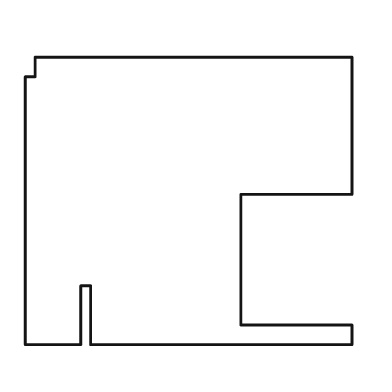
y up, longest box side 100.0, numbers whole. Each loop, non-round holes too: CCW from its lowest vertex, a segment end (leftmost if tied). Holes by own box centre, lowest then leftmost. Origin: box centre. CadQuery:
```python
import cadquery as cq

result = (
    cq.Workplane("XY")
    .moveTo(-50.0, -44.0)
    .lineTo(-33.0, -44.0)
    .lineTo(-33.0, -26.0)
    .lineTo(-30.0, -26.0)
    .lineTo(-30.0, -44.0)
    .lineTo(50.0, -44.0)
    .lineTo(50.0, -38.0)
    .lineTo(16.0, -38.0)
    .lineTo(16.0, 2.0)
    .lineTo(50.0, 2.0)
    .lineTo(50.0, 44.0)
    .lineTo(-47.0, 44.0)
    .lineTo(-47.0, 38.0)
    .lineTo(-50.0, 38.0)
    .close()
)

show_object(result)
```